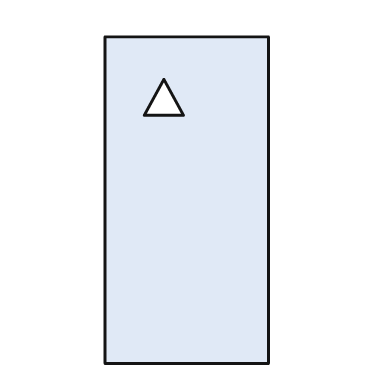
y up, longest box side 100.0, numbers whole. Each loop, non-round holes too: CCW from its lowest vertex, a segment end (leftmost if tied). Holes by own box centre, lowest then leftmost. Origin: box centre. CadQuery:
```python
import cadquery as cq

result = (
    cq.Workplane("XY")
    .moveTo(-25.0, -50.0)
    .lineTo(25.0, -50.0)
    .lineTo(25.0, 50.0)
    .lineTo(-25.0, 50.0)
    .close()
    .moveTo(-13.0, 26.0)
    .lineTo(-1.0, 26.0)
    .lineTo(-7.0, 37.0)
    .close()
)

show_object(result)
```